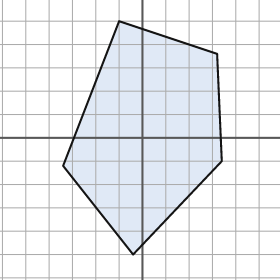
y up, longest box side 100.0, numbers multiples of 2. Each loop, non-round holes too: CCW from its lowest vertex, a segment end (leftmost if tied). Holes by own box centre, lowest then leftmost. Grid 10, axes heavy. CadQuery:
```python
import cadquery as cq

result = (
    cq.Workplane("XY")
    .moveTo(-4.0, -50.0)
    .lineTo(34.0, -10.0)
    .lineTo(32.0, 36.0)
    .lineTo(-10.0, 50.0)
    .lineTo(-34.0, -12.0)
    .close()
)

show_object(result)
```